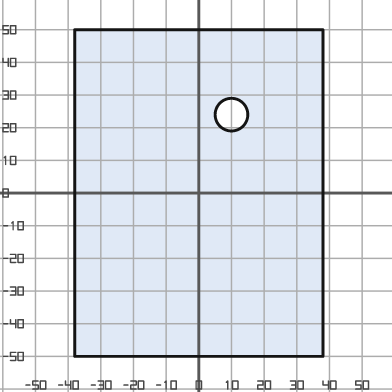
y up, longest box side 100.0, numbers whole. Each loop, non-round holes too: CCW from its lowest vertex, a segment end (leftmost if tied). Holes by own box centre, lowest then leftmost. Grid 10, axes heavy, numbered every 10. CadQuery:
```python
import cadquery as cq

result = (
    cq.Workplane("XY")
    .moveTo(-38.0, -50.0)
    .lineTo(38.0, -50.0)
    .lineTo(38.0, 50.0)
    .lineTo(-38.0, 50.0)
    .close()
    .moveTo(10.0, 24.0)
    .circle(5.0)
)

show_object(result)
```